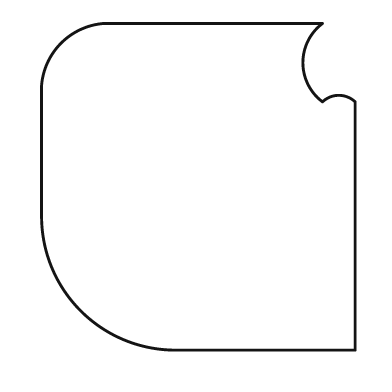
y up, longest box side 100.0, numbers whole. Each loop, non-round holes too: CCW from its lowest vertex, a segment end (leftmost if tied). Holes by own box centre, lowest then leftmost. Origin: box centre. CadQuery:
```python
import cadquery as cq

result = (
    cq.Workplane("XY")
    .moveTo(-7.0, -50.0)
    .lineTo(48.0, -50.0)
    .lineTo(48.0, 26.0)
    .threePointArc((43.0, 28.0), (38.0, 26.0))
    .threePointArc((32.0, 38.0), (38.0, 50.0))
    .lineTo(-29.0, 50.0)
    .threePointArc((-42.0, 44.0), (-48.0, 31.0))
    .lineTo(-48.0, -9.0)
    .threePointArc((-36.0, -38.0), (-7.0, -50.0))
    .close()
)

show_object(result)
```